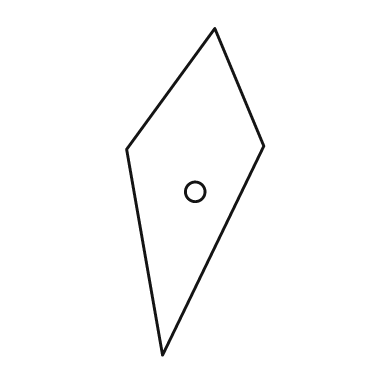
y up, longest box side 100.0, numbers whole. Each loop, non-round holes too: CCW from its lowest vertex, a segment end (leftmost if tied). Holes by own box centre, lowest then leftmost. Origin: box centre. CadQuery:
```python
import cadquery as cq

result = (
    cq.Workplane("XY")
    .moveTo(-10.0, -50.0)
    .lineTo(21.0, 14.0)
    .lineTo(6.0, 50.0)
    .lineTo(-21.0, 13.0)
    .close()
    .moveTo(0.0, 0.0)
    .circle(3.0)
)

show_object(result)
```